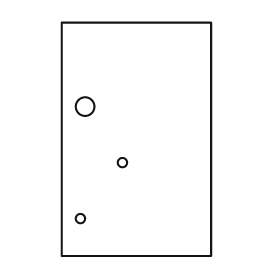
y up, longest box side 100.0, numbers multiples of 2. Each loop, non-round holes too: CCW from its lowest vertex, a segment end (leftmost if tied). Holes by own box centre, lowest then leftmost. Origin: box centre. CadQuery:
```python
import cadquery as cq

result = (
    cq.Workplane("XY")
    .moveTo(-32.0, -50.0)
    .lineTo(32.0, -50.0)
    .lineTo(32.0, 50.0)
    .lineTo(-32.0, 50.0)
    .close()
    .moveTo(-24.0, -34.0)
    .circle(2.0)
    .moveTo(-6.0, -10.0)
    .circle(2.0)
    .moveTo(-22.0, 14.0)
    .circle(4.0)
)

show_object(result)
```